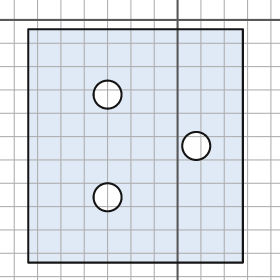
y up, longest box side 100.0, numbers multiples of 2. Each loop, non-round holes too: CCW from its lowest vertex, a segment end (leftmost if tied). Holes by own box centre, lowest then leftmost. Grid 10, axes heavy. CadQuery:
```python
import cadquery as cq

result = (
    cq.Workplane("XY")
    .moveTo(-64.0, -104.0)
    .lineTo(28.0, -104.0)
    .lineTo(28.0, -4.0)
    .lineTo(-64.0, -4.0)
    .close()
    .moveTo(-30.0, -76.0)
    .circle(6.0)
    .moveTo(8.0, -54.0)
    .circle(6.0)
    .moveTo(-30.0, -32.0)
    .circle(6.0)
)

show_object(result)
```